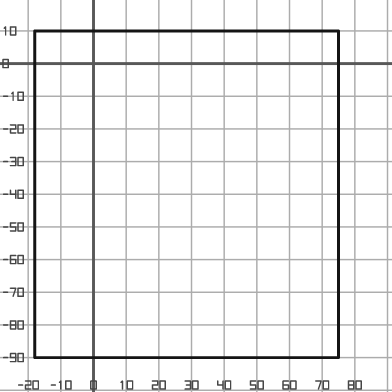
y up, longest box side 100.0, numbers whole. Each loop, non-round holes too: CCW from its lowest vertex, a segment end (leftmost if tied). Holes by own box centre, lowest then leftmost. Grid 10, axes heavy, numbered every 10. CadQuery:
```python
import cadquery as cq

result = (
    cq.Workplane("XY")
    .moveTo(-18.0, -90.0)
    .lineTo(75.0, -90.0)
    .lineTo(75.0, 10.0)
    .lineTo(-18.0, 10.0)
    .close()
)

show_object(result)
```